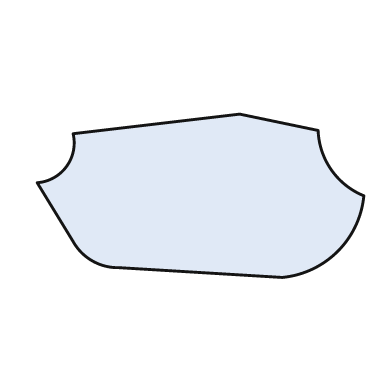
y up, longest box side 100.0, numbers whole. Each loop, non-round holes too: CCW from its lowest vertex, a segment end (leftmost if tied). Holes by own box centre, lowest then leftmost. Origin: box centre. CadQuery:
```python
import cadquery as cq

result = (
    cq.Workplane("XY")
    .moveTo(25.0, -25.0)
    .threePointArc((42.0, -17.0), (50.0, 0.0))
    .threePointArc((40.0, 8.0), (36.0, 20.0))
    .lineTo(12.0, 25.0)
    .lineTo(-39.0, 19.0)
    .threePointArc((-41.0, 9.0), (-50.0, 4.0))
    .lineTo(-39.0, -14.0)
    .threePointArc((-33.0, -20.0), (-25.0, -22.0))
    .close()
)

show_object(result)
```